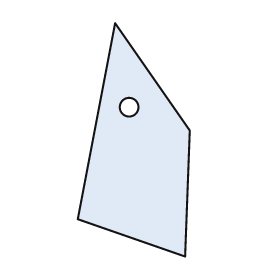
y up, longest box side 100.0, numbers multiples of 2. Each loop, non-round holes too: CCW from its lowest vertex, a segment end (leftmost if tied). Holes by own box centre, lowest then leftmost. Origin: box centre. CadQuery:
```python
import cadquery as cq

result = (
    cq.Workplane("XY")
    .moveTo(22.0, -50.0)
    .lineTo(24.0, 4.0)
    .lineTo(-8.0, 50.0)
    .lineTo(-24.0, -34.0)
    .close()
    .moveTo(-2.0, 14.0)
    .circle(4.0)
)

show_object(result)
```